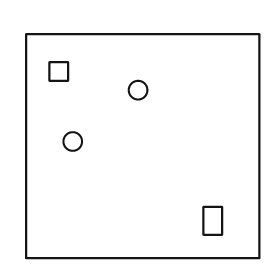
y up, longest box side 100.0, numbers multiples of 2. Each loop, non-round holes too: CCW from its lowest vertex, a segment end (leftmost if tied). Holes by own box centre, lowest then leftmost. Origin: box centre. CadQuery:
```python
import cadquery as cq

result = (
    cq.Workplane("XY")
    .moveTo(-50.0, -48.0)
    .lineTo(50.0, -48.0)
    .lineTo(50.0, 48.0)
    .lineTo(-50.0, 48.0)
    .close()
    .moveTo(26.0, -38.0)
    .lineTo(34.0, -38.0)
    .lineTo(34.0, -26.0)
    .lineTo(26.0, -26.0)
    .close()
    .moveTo(-30.0, 2.0)
    .circle(4.0)
    .moveTo(-2.0, 24.0)
    .circle(4.0)
    .moveTo(-40.0, 28.0)
    .lineTo(-32.0, 28.0)
    .lineTo(-32.0, 36.0)
    .lineTo(-40.0, 36.0)
    .close()
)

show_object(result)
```